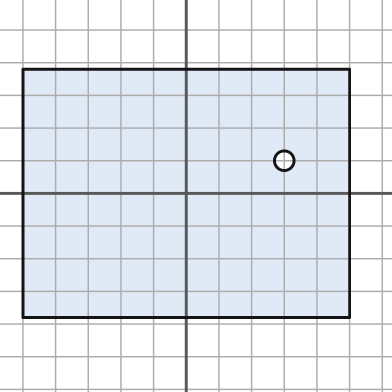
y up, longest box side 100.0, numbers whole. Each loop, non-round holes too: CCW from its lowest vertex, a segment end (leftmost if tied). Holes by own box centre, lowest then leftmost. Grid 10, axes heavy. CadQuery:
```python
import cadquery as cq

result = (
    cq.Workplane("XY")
    .moveTo(-50.0, -38.0)
    .lineTo(50.0, -38.0)
    .lineTo(50.0, 38.0)
    .lineTo(-50.0, 38.0)
    .close()
    .moveTo(30.0, 10.0)
    .circle(3.0)
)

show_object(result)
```